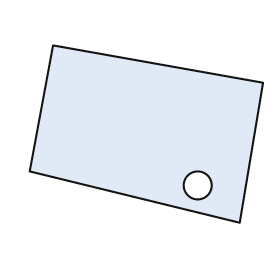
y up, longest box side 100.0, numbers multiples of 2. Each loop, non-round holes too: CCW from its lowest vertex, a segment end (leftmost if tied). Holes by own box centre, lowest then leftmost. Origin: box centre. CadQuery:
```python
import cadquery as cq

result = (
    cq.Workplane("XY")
    .moveTo(40.0, -38.0)
    .lineTo(50.0, 22.0)
    .lineTo(-40.0, 38.0)
    .lineTo(-50.0, -16.0)
    .close()
    .moveTo(22.0, -22.0)
    .circle(6.0)
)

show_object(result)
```